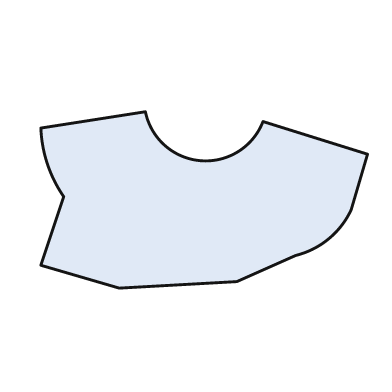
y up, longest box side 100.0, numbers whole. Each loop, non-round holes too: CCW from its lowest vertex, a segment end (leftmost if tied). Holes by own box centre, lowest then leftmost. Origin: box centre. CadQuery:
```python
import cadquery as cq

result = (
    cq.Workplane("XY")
    .moveTo(-26.0, -27.0)
    .lineTo(10.0, -25.0)
    .lineTo(28.0, -17.0)
    .threePointArc((38.0, -12.0), (45.0, -3.0))
    .lineTo(50.0, 14.0)
    .lineTo(18.0, 24.0)
    .threePointArc((-1.0, 12.0), (-18.0, 27.0))
    .lineTo(-50.0, 22.0)
    .threePointArc((-48.0, 11.0), (-43.0, 1.0))
    .lineTo(-50.0, -20.0)
    .close()
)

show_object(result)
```